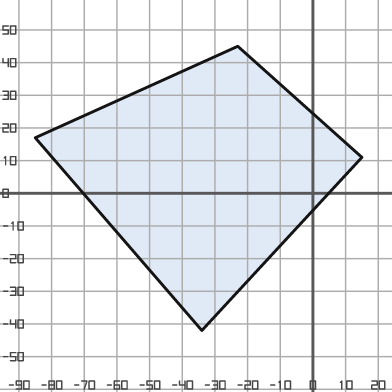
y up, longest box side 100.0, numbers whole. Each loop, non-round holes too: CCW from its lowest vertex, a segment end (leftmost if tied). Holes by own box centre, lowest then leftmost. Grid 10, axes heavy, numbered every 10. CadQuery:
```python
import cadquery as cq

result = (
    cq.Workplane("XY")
    .moveTo(-34.0, -42.0)
    .lineTo(15.0, 11.0)
    .lineTo(-23.0, 45.0)
    .lineTo(-85.0, 17.0)
    .close()
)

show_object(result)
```